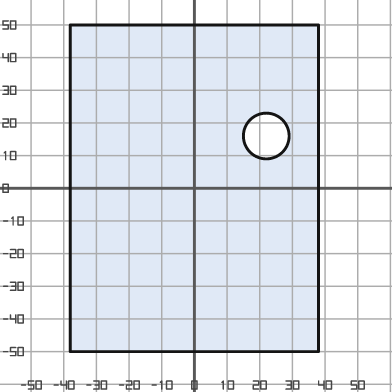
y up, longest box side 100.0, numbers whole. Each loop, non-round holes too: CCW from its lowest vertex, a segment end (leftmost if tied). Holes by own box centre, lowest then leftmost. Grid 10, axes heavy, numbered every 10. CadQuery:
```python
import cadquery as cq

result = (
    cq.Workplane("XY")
    .moveTo(-38.0, -50.0)
    .lineTo(38.0, -50.0)
    .lineTo(38.0, 50.0)
    .lineTo(-38.0, 50.0)
    .close()
    .moveTo(22.0, 16.0)
    .circle(7.0)
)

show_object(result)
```